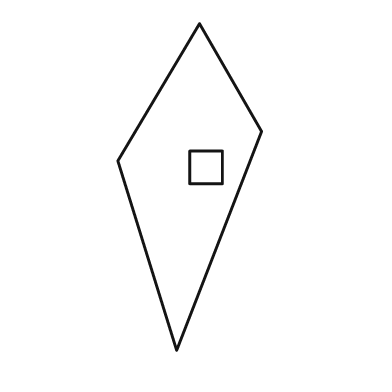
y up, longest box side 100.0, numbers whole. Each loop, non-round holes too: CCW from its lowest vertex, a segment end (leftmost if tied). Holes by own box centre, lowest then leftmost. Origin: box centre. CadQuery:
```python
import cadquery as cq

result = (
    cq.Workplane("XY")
    .moveTo(-4.0, -50.0)
    .lineTo(22.0, 17.0)
    .lineTo(3.0, 50.0)
    .lineTo(-22.0, 8.0)
    .close()
    .moveTo(0.0, 1.0)
    .lineTo(10.0, 1.0)
    .lineTo(10.0, 11.0)
    .lineTo(0.0, 11.0)
    .close()
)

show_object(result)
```